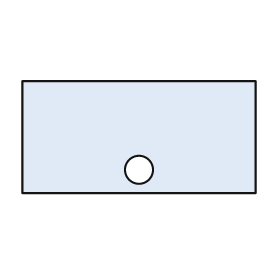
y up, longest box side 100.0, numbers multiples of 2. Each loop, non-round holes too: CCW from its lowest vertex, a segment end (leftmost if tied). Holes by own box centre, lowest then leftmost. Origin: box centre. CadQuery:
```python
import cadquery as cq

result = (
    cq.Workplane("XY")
    .moveTo(-50.0, -24.0)
    .lineTo(50.0, -24.0)
    .lineTo(50.0, 24.0)
    .lineTo(-50.0, 24.0)
    .close()
    .moveTo(0.0, -14.0)
    .circle(6.0)
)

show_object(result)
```